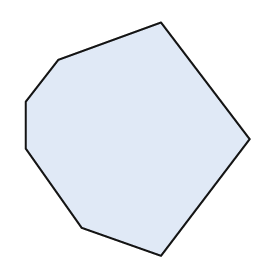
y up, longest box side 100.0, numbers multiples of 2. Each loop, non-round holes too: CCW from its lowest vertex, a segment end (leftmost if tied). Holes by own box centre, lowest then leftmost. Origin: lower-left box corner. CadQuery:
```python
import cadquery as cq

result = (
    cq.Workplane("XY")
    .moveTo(58.0, 0.0)
    .lineTo(96.0, 50.0)
    .lineTo(58.0, 100.0)
    .lineTo(14.0, 84.0)
    .lineTo(0.0, 66.0)
    .lineTo(0.0, 46.0)
    .lineTo(24.0, 12.0)
    .close()
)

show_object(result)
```